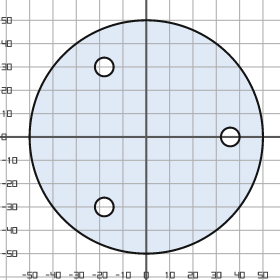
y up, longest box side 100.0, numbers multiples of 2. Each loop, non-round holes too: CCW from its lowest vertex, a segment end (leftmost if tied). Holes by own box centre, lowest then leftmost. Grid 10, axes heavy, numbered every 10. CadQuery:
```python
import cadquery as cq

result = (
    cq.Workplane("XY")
    .moveTo(0.0, 0.0)
    .circle(50.0)
    .moveTo(-18.0, -30.0)
    .circle(4.0)
    .moveTo(36.0, 0.0)
    .circle(4.0)
    .moveTo(-18.0, 30.0)
    .circle(4.0)
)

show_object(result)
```